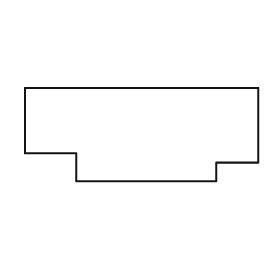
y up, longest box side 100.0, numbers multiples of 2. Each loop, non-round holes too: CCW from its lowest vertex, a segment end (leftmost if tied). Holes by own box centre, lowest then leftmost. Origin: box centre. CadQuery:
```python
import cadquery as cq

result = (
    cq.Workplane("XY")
    .moveTo(-28.0, -20.0)
    .lineTo(32.0, -20.0)
    .lineTo(32.0, -12.0)
    .lineTo(50.0, -12.0)
    .lineTo(50.0, 20.0)
    .lineTo(-50.0, 20.0)
    .lineTo(-50.0, -8.0)
    .lineTo(-28.0, -8.0)
    .close()
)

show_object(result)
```